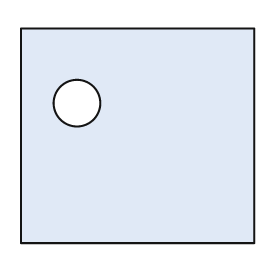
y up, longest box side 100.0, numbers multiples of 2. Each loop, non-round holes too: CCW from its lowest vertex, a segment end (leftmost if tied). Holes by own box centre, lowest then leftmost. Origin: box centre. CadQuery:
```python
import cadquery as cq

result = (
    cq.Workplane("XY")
    .moveTo(-50.0, -46.0)
    .lineTo(50.0, -46.0)
    .lineTo(50.0, 46.0)
    .lineTo(-50.0, 46.0)
    .close()
    .moveTo(-26.0, 14.0)
    .circle(10.0)
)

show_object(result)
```